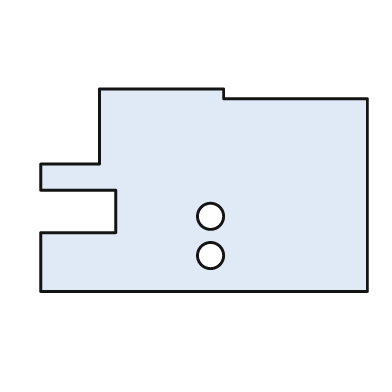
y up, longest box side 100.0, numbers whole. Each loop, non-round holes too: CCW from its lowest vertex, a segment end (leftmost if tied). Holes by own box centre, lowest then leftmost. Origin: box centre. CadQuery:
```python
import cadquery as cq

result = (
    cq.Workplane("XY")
    .moveTo(-50.0, -31.0)
    .lineTo(50.0, -31.0)
    .lineTo(50.0, 28.0)
    .lineTo(6.0, 28.0)
    .lineTo(6.0, 31.0)
    .lineTo(-32.0, 31.0)
    .lineTo(-32.0, 8.0)
    .lineTo(-50.0, 8.0)
    .lineTo(-50.0, 0.0)
    .lineTo(-27.0, 0.0)
    .lineTo(-27.0, -13.0)
    .lineTo(-50.0, -13.0)
    .close()
    .moveTo(2.0, -20.0)
    .circle(4.0)
    .moveTo(2.0, -8.0)
    .circle(4.0)
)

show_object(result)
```